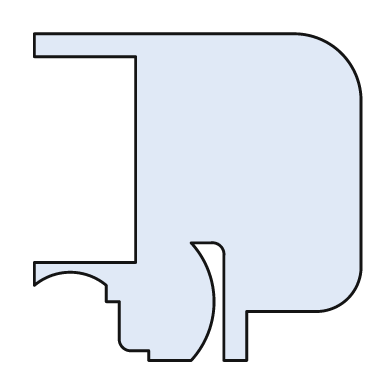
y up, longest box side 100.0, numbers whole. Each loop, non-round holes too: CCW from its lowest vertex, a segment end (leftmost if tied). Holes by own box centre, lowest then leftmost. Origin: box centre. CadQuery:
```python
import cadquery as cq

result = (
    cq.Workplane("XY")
    .moveTo(-15.0, -50.0)
    .lineTo(-2.0, -50.0)
    .threePointArc((5.0, -32.0), (-2.0, -14.0))
    .lineTo(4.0, -14.0)
    .threePointArc((7.0, -15.0), (8.0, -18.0))
    .lineTo(8.0, -50.0)
    .lineTo(15.0, -50.0)
    .lineTo(15.0, -35.0)
    .lineTo(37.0, -35.0)
    .threePointArc((46.0, -31.0), (50.0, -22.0))
    .lineTo(50.0, 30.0)
    .threePointArc((44.0, 44.0), (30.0, 50.0))
    .lineTo(-50.0, 50.0)
    .lineTo(-50.0, 43.0)
    .lineTo(-19.0, 43.0)
    .lineTo(-19.0, -20.0)
    .lineTo(-50.0, -20.0)
    .lineTo(-50.0, -27.0)
    .threePointArc((-39.0, -23.0), (-28.0, -27.0))
    .lineTo(-28.0, -32.0)
    .lineTo(-24.0, -32.0)
    .lineTo(-24.0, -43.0)
    .threePointArc((-23.0, -46.0), (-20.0, -47.0))
    .lineTo(-15.0, -47.0)
    .close()
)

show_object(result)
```